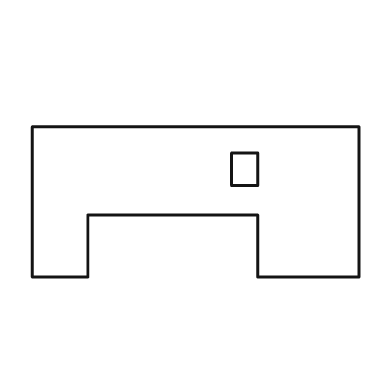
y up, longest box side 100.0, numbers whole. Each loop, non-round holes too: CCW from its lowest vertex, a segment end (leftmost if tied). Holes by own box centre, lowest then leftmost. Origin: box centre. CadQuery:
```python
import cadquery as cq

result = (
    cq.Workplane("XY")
    .moveTo(-50.0, -23.0)
    .lineTo(-33.0, -23.0)
    .lineTo(-33.0, -4.0)
    .lineTo(19.0, -4.0)
    .lineTo(19.0, -23.0)
    .lineTo(50.0, -23.0)
    .lineTo(50.0, 23.0)
    .lineTo(-50.0, 23.0)
    .close()
    .moveTo(11.0, 5.0)
    .lineTo(19.0, 5.0)
    .lineTo(19.0, 15.0)
    .lineTo(11.0, 15.0)
    .close()
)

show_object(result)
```